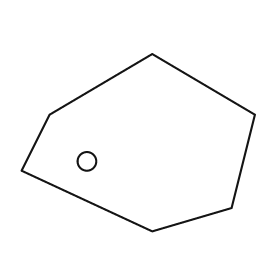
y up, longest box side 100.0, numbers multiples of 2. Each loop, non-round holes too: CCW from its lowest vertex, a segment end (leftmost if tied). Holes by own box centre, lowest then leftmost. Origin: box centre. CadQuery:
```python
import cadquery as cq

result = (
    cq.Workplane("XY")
    .moveTo(6.0, -38.0)
    .lineTo(40.0, -28.0)
    .lineTo(50.0, 12.0)
    .lineTo(6.0, 38.0)
    .lineTo(-38.0, 12.0)
    .lineTo(-50.0, -12.0)
    .close()
    .moveTo(-22.0, -8.0)
    .circle(4.0)
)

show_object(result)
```